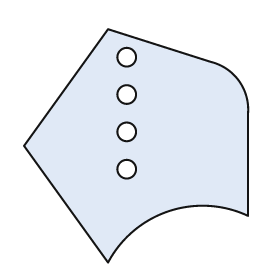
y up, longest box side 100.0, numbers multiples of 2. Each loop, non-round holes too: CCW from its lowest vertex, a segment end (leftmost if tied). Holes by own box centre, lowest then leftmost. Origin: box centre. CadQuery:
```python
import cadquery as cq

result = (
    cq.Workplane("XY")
    .moveTo(-12.0, -50.0)
    .threePointArc((14.0, -28.0), (48.0, -30.0))
    .lineTo(48.0, 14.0)
    .threePointArc((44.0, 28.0), (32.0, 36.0))
    .lineTo(-12.0, 50.0)
    .lineTo(-48.0, 0.0)
    .close()
    .moveTo(-4.0, -10.0)
    .circle(4.0)
    .moveTo(-4.0, 6.0)
    .circle(4.0)
    .moveTo(-4.0, 22.0)
    .circle(4.0)
    .moveTo(-4.0, 38.0)
    .circle(4.0)
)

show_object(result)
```